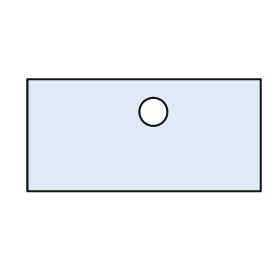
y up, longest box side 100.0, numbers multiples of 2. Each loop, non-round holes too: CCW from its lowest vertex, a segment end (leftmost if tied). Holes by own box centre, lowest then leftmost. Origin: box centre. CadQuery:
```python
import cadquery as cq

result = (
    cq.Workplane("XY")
    .moveTo(-50.0, -24.0)
    .lineTo(50.0, -24.0)
    .lineTo(50.0, 24.0)
    .lineTo(-50.0, 24.0)
    .close()
    .moveTo(4.0, 10.0)
    .circle(6.0)
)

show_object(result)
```